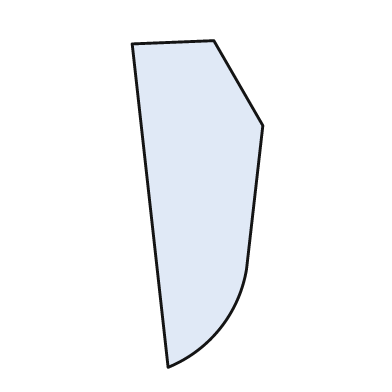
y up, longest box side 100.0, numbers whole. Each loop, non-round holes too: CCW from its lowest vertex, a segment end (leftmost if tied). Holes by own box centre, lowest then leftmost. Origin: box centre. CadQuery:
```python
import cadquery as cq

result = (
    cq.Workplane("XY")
    .moveTo(-9.0, -50.0)
    .threePointArc((7.0, -38.0), (15.0, -20.0))
    .lineTo(20.0, 24.0)
    .lineTo(5.0, 50.0)
    .lineTo(-20.0, 49.0)
    .close()
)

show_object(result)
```